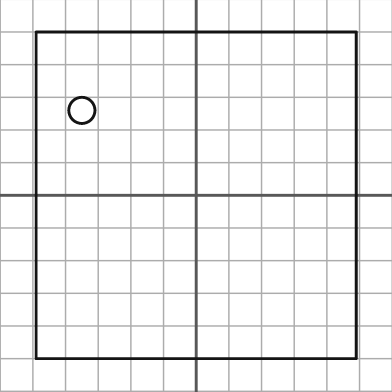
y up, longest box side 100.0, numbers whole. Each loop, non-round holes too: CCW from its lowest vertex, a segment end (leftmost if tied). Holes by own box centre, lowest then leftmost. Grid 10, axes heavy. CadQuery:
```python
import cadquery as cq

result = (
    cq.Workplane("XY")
    .moveTo(-49.0, -50.0)
    .lineTo(49.0, -50.0)
    .lineTo(49.0, 50.0)
    .lineTo(-49.0, 50.0)
    .close()
    .moveTo(-35.0, 26.0)
    .circle(4.0)
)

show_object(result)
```